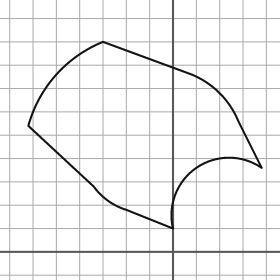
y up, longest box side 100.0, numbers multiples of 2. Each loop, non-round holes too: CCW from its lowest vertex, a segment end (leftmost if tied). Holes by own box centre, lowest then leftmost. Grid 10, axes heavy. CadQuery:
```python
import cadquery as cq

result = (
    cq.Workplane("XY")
    .moveTo(0.0, 10.0)
    .threePointArc((10.0, 36.0), (38.0, 36.0))
    .lineTo(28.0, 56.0)
    .threePointArc((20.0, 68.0), (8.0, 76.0))
    .lineTo(-30.0, 90.0)
    .threePointArc((-50.0, 76.0), (-62.0, 54.0))
    .lineTo(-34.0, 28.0)
    .threePointArc((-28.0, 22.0), (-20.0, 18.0))
    .close()
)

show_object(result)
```